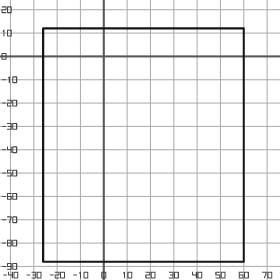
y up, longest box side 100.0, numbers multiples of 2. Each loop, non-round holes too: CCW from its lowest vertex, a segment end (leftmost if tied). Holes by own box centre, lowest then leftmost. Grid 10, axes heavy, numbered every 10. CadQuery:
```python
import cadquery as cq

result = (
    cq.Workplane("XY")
    .moveTo(-26.0, -88.0)
    .lineTo(60.0, -88.0)
    .lineTo(60.0, 12.0)
    .lineTo(-26.0, 12.0)
    .close()
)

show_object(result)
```